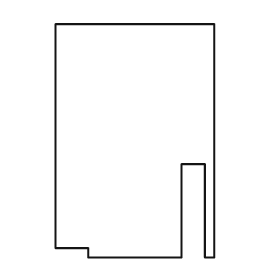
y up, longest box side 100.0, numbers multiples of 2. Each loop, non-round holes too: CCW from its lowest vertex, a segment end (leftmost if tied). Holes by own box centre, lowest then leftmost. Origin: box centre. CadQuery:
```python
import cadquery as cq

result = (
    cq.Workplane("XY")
    .moveTo(-20.0, -50.0)
    .lineTo(20.0, -50.0)
    .lineTo(20.0, -10.0)
    .lineTo(30.0, -10.0)
    .lineTo(30.0, -50.0)
    .lineTo(34.0, -50.0)
    .lineTo(34.0, 50.0)
    .lineTo(-34.0, 50.0)
    .lineTo(-34.0, -46.0)
    .lineTo(-20.0, -46.0)
    .close()
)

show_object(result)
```